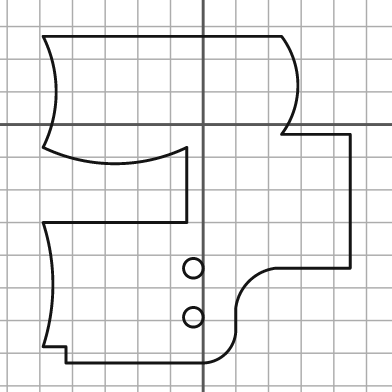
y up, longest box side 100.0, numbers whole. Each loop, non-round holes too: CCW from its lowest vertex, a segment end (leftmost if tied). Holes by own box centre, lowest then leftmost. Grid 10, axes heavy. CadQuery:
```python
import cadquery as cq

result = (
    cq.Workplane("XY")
    .moveTo(-42.0, -73.0)
    .lineTo(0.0, -73.0)
    .threePointArc((7.0, -70.0), (10.0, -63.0))
    .lineTo(10.0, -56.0)
    .threePointArc((14.0, -48.0), (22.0, -44.0))
    .lineTo(45.0, -44.0)
    .lineTo(45.0, -3.0)
    .lineTo(24.0, -3.0)
    .threePointArc((29.0, 12.0), (24.0, 27.0))
    .lineTo(-49.0, 27.0)
    .threePointArc((-45.0, 10.0), (-49.0, -7.0))
    .threePointArc((-27.0, -12.0), (-5.0, -7.0))
    .lineTo(-5.0, -30.0)
    .lineTo(-49.0, -30.0)
    .threePointArc((-46.0, -49.0), (-49.0, -68.0))
    .lineTo(-42.0, -68.0)
    .close()
    .moveTo(-3.0, -59.0)
    .circle(3.0)
    .moveTo(-3.0, -44.0)
    .circle(3.0)
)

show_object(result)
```